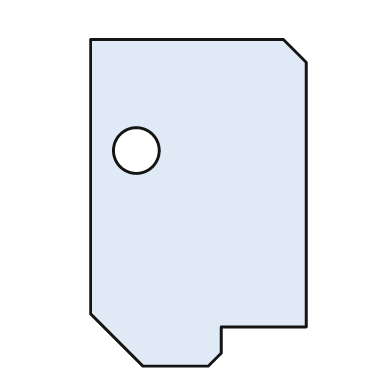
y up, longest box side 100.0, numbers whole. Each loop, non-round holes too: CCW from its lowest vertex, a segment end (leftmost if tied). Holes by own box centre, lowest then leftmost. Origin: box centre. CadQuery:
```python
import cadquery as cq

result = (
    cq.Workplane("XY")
    .moveTo(-17.0, -50.0)
    .lineTo(3.0, -50.0)
    .lineTo(7.0, -46.0)
    .lineTo(7.0, -38.0)
    .lineTo(33.0, -38.0)
    .lineTo(33.0, 43.0)
    .lineTo(26.0, 50.0)
    .lineTo(-33.0, 50.0)
    .lineTo(-33.0, -34.0)
    .close()
    .moveTo(-19.0, 16.0)
    .circle(7.0)
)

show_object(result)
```